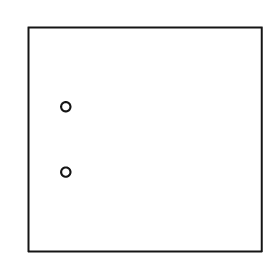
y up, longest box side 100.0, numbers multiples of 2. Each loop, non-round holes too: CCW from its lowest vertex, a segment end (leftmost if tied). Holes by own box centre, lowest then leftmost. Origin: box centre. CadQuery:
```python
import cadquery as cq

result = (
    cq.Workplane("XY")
    .moveTo(-50.0, -48.0)
    .lineTo(50.0, -48.0)
    .lineTo(50.0, 48.0)
    .lineTo(-50.0, 48.0)
    .close()
    .moveTo(-34.0, -14.0)
    .circle(2.0)
    .moveTo(-34.0, 14.0)
    .circle(2.0)
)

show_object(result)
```